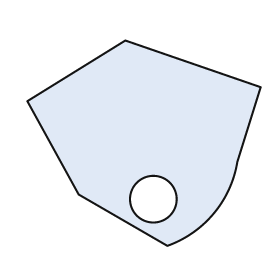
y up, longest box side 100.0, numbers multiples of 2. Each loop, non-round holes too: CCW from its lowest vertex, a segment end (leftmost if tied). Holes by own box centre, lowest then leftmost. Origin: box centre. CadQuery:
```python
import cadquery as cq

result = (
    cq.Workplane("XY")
    .moveTo(10.0, -44.0)
    .threePointArc((30.0, -30.0), (40.0, -8.0))
    .lineTo(50.0, 24.0)
    .lineTo(-8.0, 44.0)
    .lineTo(-50.0, 18.0)
    .lineTo(-28.0, -22.0)
    .close()
    .moveTo(4.0, -24.0)
    .circle(10.0)
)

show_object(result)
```